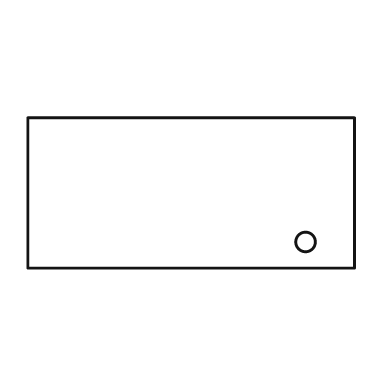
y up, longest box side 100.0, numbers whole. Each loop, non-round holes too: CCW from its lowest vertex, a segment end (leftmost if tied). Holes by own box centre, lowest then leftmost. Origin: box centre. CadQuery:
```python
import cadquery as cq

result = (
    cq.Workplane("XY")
    .moveTo(-50.0, -23.0)
    .lineTo(50.0, -23.0)
    .lineTo(50.0, 23.0)
    .lineTo(-50.0, 23.0)
    .close()
    .moveTo(35.0, -15.0)
    .circle(3.0)
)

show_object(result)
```